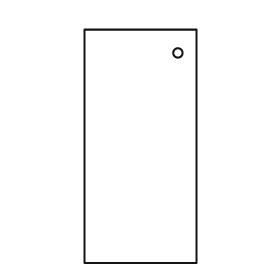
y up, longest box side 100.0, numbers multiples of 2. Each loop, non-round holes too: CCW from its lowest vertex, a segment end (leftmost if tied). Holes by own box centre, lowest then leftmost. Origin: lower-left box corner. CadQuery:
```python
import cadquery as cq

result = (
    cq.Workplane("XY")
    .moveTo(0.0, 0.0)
    .lineTo(48.0, 0.0)
    .lineTo(48.0, 100.0)
    .lineTo(0.0, 100.0)
    .close()
    .moveTo(40.0, 90.0)
    .circle(2.0)
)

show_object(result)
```